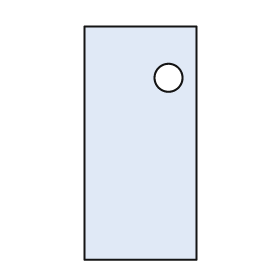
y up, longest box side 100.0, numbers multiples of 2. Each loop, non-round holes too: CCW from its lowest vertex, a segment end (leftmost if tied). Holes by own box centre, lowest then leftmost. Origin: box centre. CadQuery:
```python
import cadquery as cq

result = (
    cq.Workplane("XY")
    .moveTo(-24.0, -50.0)
    .lineTo(24.0, -50.0)
    .lineTo(24.0, 50.0)
    .lineTo(-24.0, 50.0)
    .close()
    .moveTo(12.0, 28.0)
    .circle(6.0)
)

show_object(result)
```